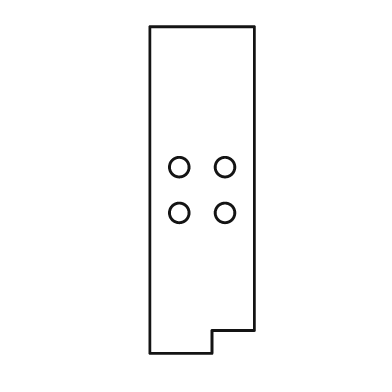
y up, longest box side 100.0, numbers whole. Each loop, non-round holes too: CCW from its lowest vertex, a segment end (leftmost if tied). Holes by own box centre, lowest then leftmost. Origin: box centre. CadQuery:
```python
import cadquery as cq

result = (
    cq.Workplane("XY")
    .moveTo(-16.0, -50.0)
    .lineTo(3.0, -50.0)
    .lineTo(3.0, -43.0)
    .lineTo(16.0, -43.0)
    .lineTo(16.0, 50.0)
    .lineTo(-16.0, 50.0)
    .close()
    .moveTo(-7.0, -7.0)
    .circle(3.0)
    .moveTo(7.0, -7.0)
    .circle(3.0)
    .moveTo(-7.0, 7.0)
    .circle(3.0)
    .moveTo(7.0, 7.0)
    .circle(3.0)
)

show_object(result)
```